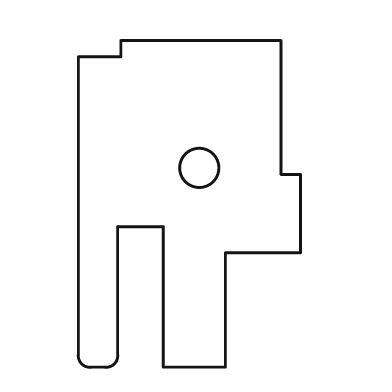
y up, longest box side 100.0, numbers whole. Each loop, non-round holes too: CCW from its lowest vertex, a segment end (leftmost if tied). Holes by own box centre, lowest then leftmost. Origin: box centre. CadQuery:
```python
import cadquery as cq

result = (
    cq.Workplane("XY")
    .moveTo(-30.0, -50.0)
    .lineTo(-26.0, -50.0)
    .threePointArc((-23.0, -49.0), (-22.0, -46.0))
    .lineTo(-22.0, -7.0)
    .lineTo(-8.0, -7.0)
    .lineTo(-8.0, -50.0)
    .lineTo(11.0, -50.0)
    .lineTo(11.0, -15.0)
    .lineTo(34.0, -15.0)
    .lineTo(34.0, 9.0)
    .lineTo(28.0, 9.0)
    .lineTo(28.0, 50.0)
    .lineTo(-21.0, 50.0)
    .lineTo(-21.0, 45.0)
    .lineTo(-34.0, 45.0)
    .lineTo(-34.0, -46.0)
    .threePointArc((-33.0, -49.0), (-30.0, -50.0))
    .close()
    .moveTo(3.0, 11.0)
    .circle(6.0)
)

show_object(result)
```